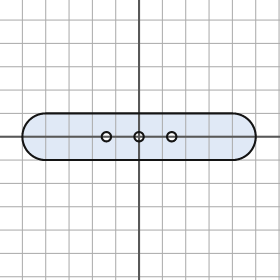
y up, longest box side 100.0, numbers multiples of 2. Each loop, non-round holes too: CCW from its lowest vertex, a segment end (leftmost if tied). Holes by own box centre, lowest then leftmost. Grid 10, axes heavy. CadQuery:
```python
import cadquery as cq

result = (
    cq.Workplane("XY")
    .moveTo(-40.0, -10.0)
    .lineTo(40.0, -10.0)
    .threePointArc((50.0, 0.0), (40.0, 10.0))
    .lineTo(-40.0, 10.0)
    .threePointArc((-50.0, 0.0), (-40.0, -10.0))
    .close()
    .moveTo(-14.0, 0.0)
    .circle(2.0)
    .moveTo(0.0, 0.0)
    .circle(2.0)
    .moveTo(14.0, 0.0)
    .circle(2.0)
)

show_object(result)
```